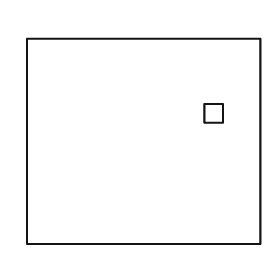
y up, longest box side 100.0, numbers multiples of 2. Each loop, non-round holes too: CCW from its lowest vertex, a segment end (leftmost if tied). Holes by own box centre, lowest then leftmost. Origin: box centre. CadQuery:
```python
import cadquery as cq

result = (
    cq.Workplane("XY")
    .moveTo(-50.0, -44.0)
    .lineTo(50.0, -44.0)
    .lineTo(50.0, 44.0)
    .lineTo(-50.0, 44.0)
    .close()
    .moveTo(26.0, 8.0)
    .lineTo(34.0, 8.0)
    .lineTo(34.0, 16.0)
    .lineTo(26.0, 16.0)
    .close()
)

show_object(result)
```